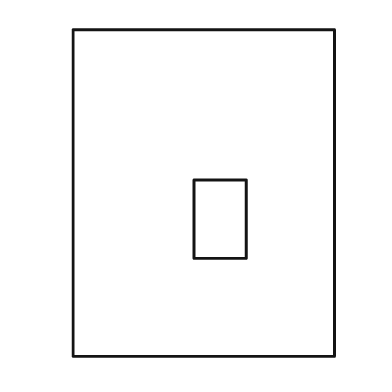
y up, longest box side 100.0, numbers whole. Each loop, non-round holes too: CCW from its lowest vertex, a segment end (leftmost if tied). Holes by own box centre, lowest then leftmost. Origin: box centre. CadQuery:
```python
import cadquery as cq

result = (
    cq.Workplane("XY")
    .moveTo(-40.0, -50.0)
    .lineTo(40.0, -50.0)
    .lineTo(40.0, 50.0)
    .lineTo(-40.0, 50.0)
    .close()
    .moveTo(-3.0, -20.0)
    .lineTo(13.0, -20.0)
    .lineTo(13.0, 4.0)
    .lineTo(-3.0, 4.0)
    .close()
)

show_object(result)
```